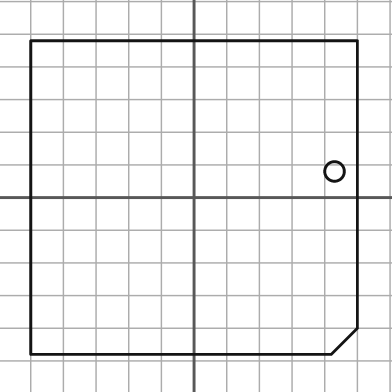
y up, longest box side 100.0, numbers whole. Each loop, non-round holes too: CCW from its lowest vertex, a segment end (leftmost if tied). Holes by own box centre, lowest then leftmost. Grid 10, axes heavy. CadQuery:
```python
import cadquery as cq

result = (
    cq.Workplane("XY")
    .moveTo(-50.0, -48.0)
    .lineTo(42.0, -48.0)
    .lineTo(50.0, -40.0)
    .lineTo(50.0, 48.0)
    .lineTo(-50.0, 48.0)
    .close()
    .moveTo(43.0, 8.0)
    .circle(3.0)
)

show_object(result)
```